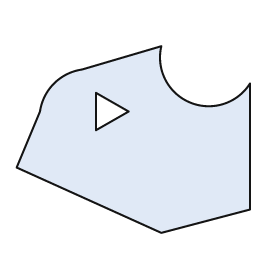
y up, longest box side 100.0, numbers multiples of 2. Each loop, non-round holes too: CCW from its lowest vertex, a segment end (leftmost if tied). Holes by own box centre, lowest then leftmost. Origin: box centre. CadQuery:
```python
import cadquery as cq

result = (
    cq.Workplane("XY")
    .moveTo(12.0, -40.0)
    .lineTo(50.0, -30.0)
    .lineTo(50.0, 24.0)
    .threePointArc((24.0, 16.0), (12.0, 40.0))
    .lineTo(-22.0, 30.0)
    .threePointArc((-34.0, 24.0), (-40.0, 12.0))
    .lineTo(-50.0, -12.0)
    .close()
    .moveTo(-16.0, 4.0)
    .lineTo(-2.0, 12.0)
    .lineTo(-16.0, 20.0)
    .close()
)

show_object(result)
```